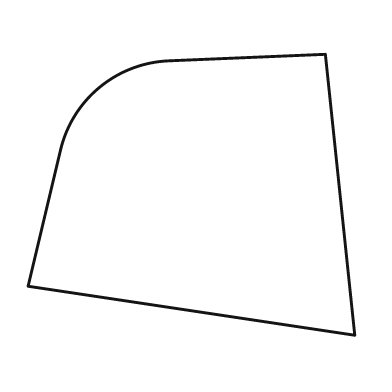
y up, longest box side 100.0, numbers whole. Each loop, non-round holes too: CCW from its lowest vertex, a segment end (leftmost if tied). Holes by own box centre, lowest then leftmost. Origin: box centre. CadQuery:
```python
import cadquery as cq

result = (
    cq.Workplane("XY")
    .moveTo(50.0, -43.0)
    .lineTo(41.0, 43.0)
    .lineTo(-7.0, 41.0)
    .threePointArc((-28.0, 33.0), (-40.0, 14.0))
    .lineTo(-50.0, -28.0)
    .close()
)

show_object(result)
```